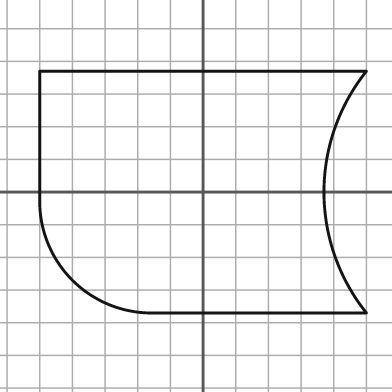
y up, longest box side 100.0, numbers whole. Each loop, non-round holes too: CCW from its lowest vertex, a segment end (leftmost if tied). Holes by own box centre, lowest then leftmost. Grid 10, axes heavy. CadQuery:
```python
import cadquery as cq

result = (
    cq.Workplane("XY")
    .moveTo(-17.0, -37.0)
    .lineTo(50.0, -37.0)
    .threePointArc((37.0, 0.0), (50.0, 37.0))
    .lineTo(-50.0, 37.0)
    .lineTo(-50.0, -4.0)
    .threePointArc((-40.0, -27.0), (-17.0, -37.0))
    .close()
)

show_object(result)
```